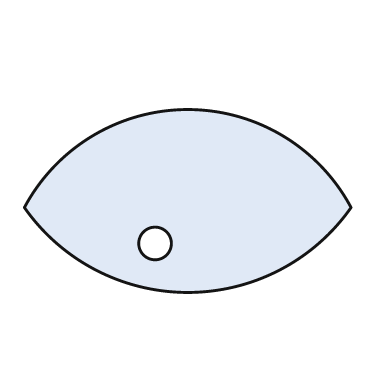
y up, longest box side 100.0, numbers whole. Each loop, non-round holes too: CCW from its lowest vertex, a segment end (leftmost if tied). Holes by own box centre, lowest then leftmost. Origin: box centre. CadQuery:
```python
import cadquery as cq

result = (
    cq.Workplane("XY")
    .moveTo(-50.0, -2.0)
    .threePointArc((0.0, -28.0), (50.0, -2.0))
    .threePointArc((0.0, 28.0), (-50.0, -2.0))
    .close()
    .moveTo(-10.0, -13.0)
    .circle(5.0)
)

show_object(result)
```